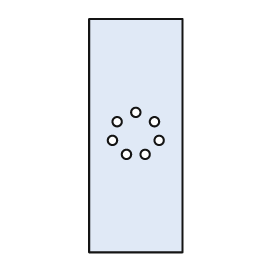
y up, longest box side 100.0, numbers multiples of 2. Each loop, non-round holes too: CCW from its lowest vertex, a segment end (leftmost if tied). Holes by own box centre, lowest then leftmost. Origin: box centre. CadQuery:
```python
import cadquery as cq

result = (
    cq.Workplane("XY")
    .moveTo(-20.0, -50.0)
    .lineTo(20.0, -50.0)
    .lineTo(20.0, 50.0)
    .lineTo(-20.0, 50.0)
    .close()
    .moveTo(-4.0, -8.0)
    .circle(2.0)
    .moveTo(4.0, -8.0)
    .circle(2.0)
    .moveTo(-10.0, -2.0)
    .circle(2.0)
    .moveTo(10.0, -2.0)
    .circle(2.0)
    .moveTo(-8.0, 6.0)
    .circle(2.0)
    .moveTo(8.0, 6.0)
    .circle(2.0)
    .moveTo(0.0, 10.0)
    .circle(2.0)
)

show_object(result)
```